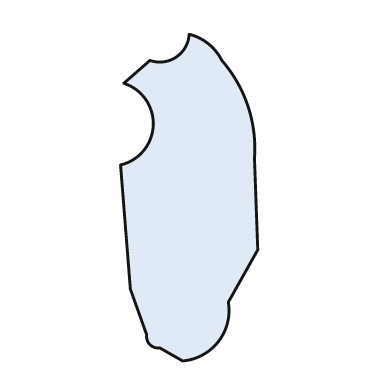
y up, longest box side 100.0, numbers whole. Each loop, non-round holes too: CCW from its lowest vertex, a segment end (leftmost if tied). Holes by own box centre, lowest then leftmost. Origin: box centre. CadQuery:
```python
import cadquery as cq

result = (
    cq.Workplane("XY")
    .moveTo(-2.0, -50.0)
    .threePointArc((9.0, -44.0), (12.0, -32.0))
    .lineTo(21.0, -16.0)
    .lineTo(20.0, 12.0)
    .threePointArc((18.0, 28.0), (10.0, 42.0))
    .threePointArc((6.0, 47.0), (0.0, 50.0))
    .threePointArc((-4.0, 43.0), (-12.0, 42.0))
    .lineTo(-20.0, 35.0)
    .threePointArc((-11.0, 22.0), (-21.0, 10.0))
    .lineTo(-18.0, -28.0)
    .lineTo(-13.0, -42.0)
    .threePointArc((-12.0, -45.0), (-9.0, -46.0))
    .close()
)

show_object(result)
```